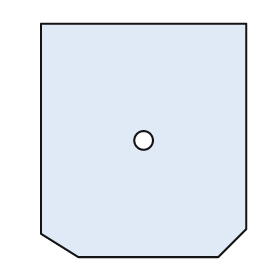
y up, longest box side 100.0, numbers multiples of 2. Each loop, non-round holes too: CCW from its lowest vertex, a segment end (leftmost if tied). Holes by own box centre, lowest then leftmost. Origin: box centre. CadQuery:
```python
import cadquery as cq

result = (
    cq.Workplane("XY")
    .moveTo(-28.0, -50.0)
    .lineTo(32.0, -50.0)
    .lineTo(44.0, -38.0)
    .lineTo(44.0, 50.0)
    .lineTo(-44.0, 50.0)
    .lineTo(-44.0, -40.0)
    .close()
    .moveTo(0.0, 0.0)
    .circle(4.0)
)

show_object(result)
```